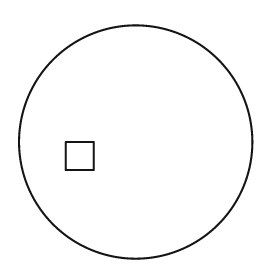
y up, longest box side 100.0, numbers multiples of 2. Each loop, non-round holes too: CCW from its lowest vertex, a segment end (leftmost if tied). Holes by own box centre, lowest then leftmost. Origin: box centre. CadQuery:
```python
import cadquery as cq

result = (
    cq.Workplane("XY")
    .moveTo(0.0, 0.0)
    .circle(50.0)
    .moveTo(-30.0, -12.0)
    .lineTo(-18.0, -12.0)
    .lineTo(-18.0, 0.0)
    .lineTo(-30.0, 0.0)
    .close()
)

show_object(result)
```